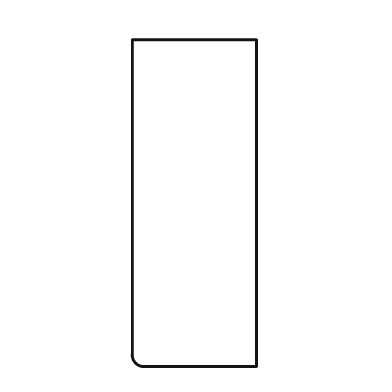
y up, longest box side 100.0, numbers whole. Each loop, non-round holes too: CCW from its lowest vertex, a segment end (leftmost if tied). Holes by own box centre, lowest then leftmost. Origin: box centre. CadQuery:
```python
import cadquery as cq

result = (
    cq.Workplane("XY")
    .moveTo(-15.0, -50.0)
    .lineTo(19.0, -50.0)
    .lineTo(19.0, 50.0)
    .lineTo(-19.0, 50.0)
    .lineTo(-19.0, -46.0)
    .threePointArc((-18.0, -49.0), (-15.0, -50.0))
    .close()
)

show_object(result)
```